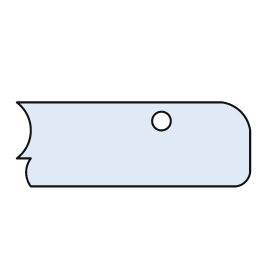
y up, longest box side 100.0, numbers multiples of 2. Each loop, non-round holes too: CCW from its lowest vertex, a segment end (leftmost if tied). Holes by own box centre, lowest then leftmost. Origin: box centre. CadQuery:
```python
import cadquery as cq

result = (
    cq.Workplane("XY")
    .moveTo(-44.0, -18.0)
    .lineTo(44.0, -18.0)
    .threePointArc((48.0, -16.0), (50.0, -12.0))
    .lineTo(50.0, 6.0)
    .threePointArc((46.0, 14.0), (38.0, 18.0))
    .lineTo(-50.0, 18.0)
    .threePointArc((-44.0, 6.0), (-50.0, -6.0))
    .lineTo(-44.0, -6.0)
    .threePointArc((-46.0, -12.0), (-44.0, -18.0))
    .close()
    .moveTo(12.0, 10.0)
    .circle(4.0)
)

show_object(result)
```